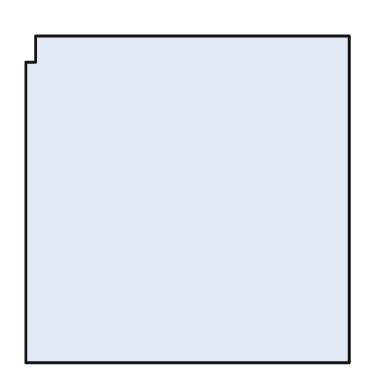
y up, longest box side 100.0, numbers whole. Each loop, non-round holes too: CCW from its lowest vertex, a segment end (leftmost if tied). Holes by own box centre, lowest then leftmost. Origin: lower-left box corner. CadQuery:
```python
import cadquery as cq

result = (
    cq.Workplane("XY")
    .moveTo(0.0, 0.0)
    .lineTo(99.0, 0.0)
    .lineTo(99.0, 100.0)
    .lineTo(3.0, 100.0)
    .lineTo(3.0, 92.0)
    .lineTo(0.0, 92.0)
    .close()
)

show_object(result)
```